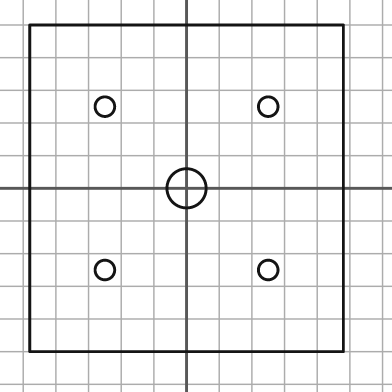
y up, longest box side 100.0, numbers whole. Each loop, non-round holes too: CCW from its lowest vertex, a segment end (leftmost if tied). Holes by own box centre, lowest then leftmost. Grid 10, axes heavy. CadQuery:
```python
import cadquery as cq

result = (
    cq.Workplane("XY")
    .moveTo(-48.0, -50.0)
    .lineTo(48.0, -50.0)
    .lineTo(48.0, 50.0)
    .lineTo(-48.0, 50.0)
    .close()
    .moveTo(-25.0, -25.0)
    .circle(3.0)
    .moveTo(25.0, -25.0)
    .circle(3.0)
    .moveTo(0.0, 0.0)
    .circle(6.0)
    .moveTo(-25.0, 25.0)
    .circle(3.0)
    .moveTo(25.0, 25.0)
    .circle(3.0)
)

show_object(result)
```